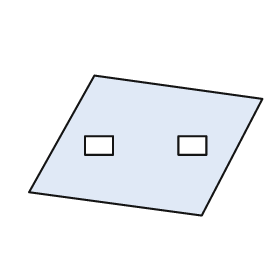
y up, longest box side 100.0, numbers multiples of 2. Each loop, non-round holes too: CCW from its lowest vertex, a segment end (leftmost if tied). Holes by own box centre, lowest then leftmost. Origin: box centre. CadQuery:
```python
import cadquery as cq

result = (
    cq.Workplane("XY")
    .moveTo(24.0, -30.0)
    .lineTo(50.0, 20.0)
    .lineTo(-22.0, 30.0)
    .lineTo(-50.0, -20.0)
    .close()
    .moveTo(-26.0, -4.0)
    .lineTo(-14.0, -4.0)
    .lineTo(-14.0, 4.0)
    .lineTo(-26.0, 4.0)
    .close()
    .moveTo(14.0, -4.0)
    .lineTo(26.0, -4.0)
    .lineTo(26.0, 4.0)
    .lineTo(14.0, 4.0)
    .close()
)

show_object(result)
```